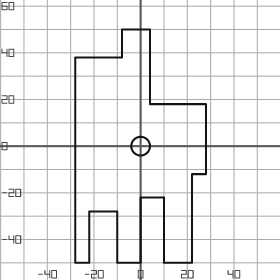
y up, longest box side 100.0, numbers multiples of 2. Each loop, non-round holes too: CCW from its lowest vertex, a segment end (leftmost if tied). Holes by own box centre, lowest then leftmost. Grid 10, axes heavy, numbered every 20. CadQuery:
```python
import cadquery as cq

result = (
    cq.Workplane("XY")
    .moveTo(-28.0, -50.0)
    .lineTo(-22.0, -50.0)
    .lineTo(-22.0, -28.0)
    .lineTo(-10.0, -28.0)
    .lineTo(-10.0, -50.0)
    .lineTo(0.0, -50.0)
    .lineTo(0.0, -22.0)
    .lineTo(10.0, -22.0)
    .lineTo(10.0, -50.0)
    .lineTo(22.0, -50.0)
    .lineTo(22.0, -12.0)
    .lineTo(28.0, -12.0)
    .lineTo(28.0, 18.0)
    .lineTo(4.0, 18.0)
    .lineTo(4.0, 50.0)
    .lineTo(-8.0, 50.0)
    .lineTo(-8.0, 38.0)
    .lineTo(-28.0, 38.0)
    .close()
    .moveTo(0.0, 0.0)
    .circle(4.0)
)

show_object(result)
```